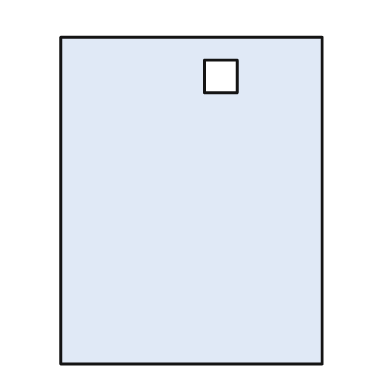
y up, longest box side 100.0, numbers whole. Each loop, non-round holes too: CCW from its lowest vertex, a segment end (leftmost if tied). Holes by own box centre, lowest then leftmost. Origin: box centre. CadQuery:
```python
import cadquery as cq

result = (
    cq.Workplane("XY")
    .moveTo(-40.0, -50.0)
    .lineTo(40.0, -50.0)
    .lineTo(40.0, 50.0)
    .lineTo(-40.0, 50.0)
    .close()
    .moveTo(4.0, 33.0)
    .lineTo(14.0, 33.0)
    .lineTo(14.0, 43.0)
    .lineTo(4.0, 43.0)
    .close()
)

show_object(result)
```